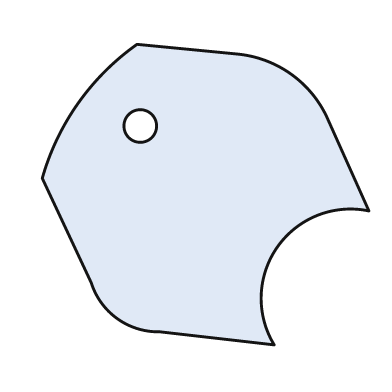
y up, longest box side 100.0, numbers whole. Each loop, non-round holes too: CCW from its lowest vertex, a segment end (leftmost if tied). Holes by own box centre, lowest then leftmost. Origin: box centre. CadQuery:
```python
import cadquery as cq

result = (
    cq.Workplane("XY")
    .moveTo(21.0, -46.0)
    .threePointArc((22.0, -16.0), (50.0, -5.0))
    .lineTo(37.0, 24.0)
    .threePointArc((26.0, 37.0), (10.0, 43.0))
    .lineTo(-21.0, 46.0)
    .threePointArc((-39.0, 28.0), (-50.0, 5.0))
    .lineTo(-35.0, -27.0)
    .threePointArc((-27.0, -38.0), (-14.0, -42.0))
    .close()
    .moveTo(-20.0, 21.0)
    .circle(5.0)
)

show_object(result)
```